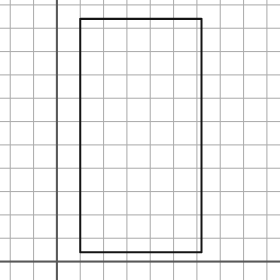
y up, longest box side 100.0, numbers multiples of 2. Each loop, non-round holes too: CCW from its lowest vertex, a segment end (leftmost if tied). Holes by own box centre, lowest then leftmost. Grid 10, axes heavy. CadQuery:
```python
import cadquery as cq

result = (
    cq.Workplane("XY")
    .moveTo(10.0, 4.0)
    .lineTo(62.0, 4.0)
    .lineTo(62.0, 104.0)
    .lineTo(10.0, 104.0)
    .close()
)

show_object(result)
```